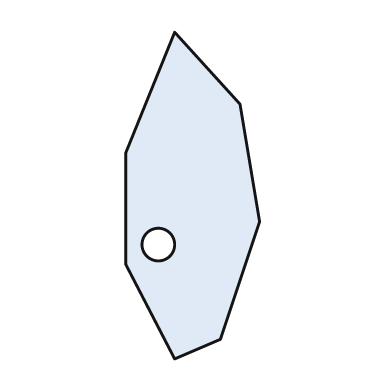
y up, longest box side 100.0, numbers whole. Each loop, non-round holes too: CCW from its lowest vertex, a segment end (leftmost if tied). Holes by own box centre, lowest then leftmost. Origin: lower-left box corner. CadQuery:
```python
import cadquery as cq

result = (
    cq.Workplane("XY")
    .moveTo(15.0, 0.0)
    .lineTo(29.0, 6.0)
    .lineTo(41.0, 42.0)
    .lineTo(35.0, 78.0)
    .lineTo(15.0, 100.0)
    .lineTo(0.0, 63.0)
    .lineTo(0.0, 29.0)
    .close()
    .moveTo(10.0, 35.0)
    .circle(5.0)
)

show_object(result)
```